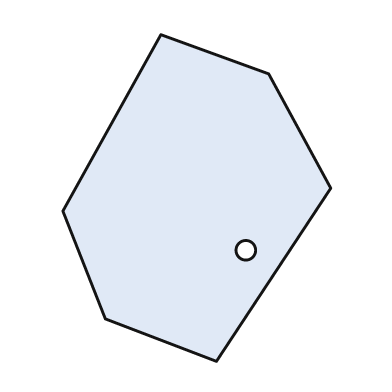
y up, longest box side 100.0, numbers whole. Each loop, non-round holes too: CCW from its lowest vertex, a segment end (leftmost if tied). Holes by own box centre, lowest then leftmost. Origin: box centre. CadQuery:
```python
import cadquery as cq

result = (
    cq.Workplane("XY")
    .moveTo(6.0, -50.0)
    .lineTo(41.0, 3.0)
    .lineTo(22.0, 38.0)
    .lineTo(-11.0, 50.0)
    .lineTo(-41.0, -4.0)
    .lineTo(-28.0, -37.0)
    .close()
    .moveTo(15.0, -16.0)
    .circle(3.0)
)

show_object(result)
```